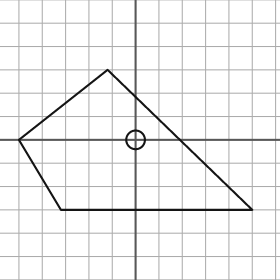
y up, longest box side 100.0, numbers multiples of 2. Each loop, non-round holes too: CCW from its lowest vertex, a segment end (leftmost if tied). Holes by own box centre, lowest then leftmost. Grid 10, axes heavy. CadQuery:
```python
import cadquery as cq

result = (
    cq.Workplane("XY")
    .moveTo(-32.0, -30.0)
    .lineTo(50.0, -30.0)
    .lineTo(-12.0, 30.0)
    .lineTo(-50.0, 0.0)
    .close()
    .moveTo(0.0, 0.0)
    .circle(4.0)
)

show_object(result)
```